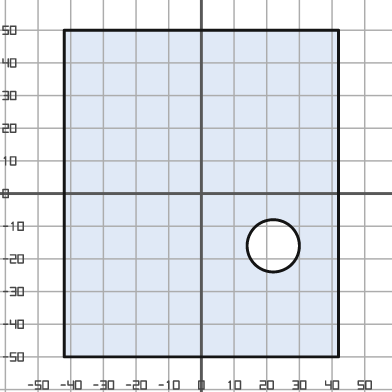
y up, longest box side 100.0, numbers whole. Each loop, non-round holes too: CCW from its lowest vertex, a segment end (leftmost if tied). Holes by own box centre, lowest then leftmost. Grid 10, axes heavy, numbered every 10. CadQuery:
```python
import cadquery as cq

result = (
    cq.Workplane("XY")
    .moveTo(-42.0, -50.0)
    .lineTo(42.0, -50.0)
    .lineTo(42.0, 50.0)
    .lineTo(-42.0, 50.0)
    .close()
    .moveTo(22.0, -16.0)
    .circle(8.0)
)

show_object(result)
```